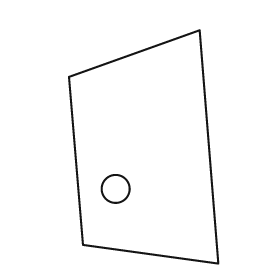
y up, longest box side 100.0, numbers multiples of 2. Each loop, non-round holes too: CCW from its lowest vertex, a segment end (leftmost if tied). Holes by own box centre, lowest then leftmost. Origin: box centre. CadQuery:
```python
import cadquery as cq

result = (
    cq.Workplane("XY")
    .moveTo(32.0, -50.0)
    .lineTo(24.0, 50.0)
    .lineTo(-32.0, 30.0)
    .lineTo(-26.0, -42.0)
    .close()
    .moveTo(-12.0, -18.0)
    .circle(6.0)
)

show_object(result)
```